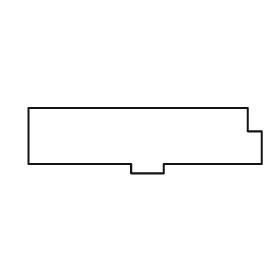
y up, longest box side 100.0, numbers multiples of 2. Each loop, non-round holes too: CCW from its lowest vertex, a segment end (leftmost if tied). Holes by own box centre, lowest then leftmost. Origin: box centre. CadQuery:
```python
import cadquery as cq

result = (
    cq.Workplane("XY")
    .moveTo(-6.0, -14.0)
    .lineTo(8.0, -14.0)
    .lineTo(8.0, -10.0)
    .lineTo(50.0, -10.0)
    .lineTo(50.0, 4.0)
    .lineTo(44.0, 4.0)
    .lineTo(44.0, 14.0)
    .lineTo(-50.0, 14.0)
    .lineTo(-50.0, -10.0)
    .lineTo(-6.0, -10.0)
    .close()
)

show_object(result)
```